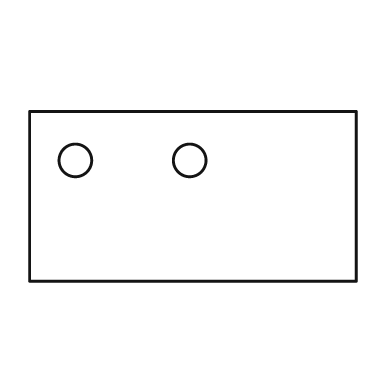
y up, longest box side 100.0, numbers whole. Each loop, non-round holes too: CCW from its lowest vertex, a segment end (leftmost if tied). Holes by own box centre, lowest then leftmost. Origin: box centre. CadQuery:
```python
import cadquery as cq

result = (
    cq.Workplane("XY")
    .moveTo(-50.0, -26.0)
    .lineTo(50.0, -26.0)
    .lineTo(50.0, 26.0)
    .lineTo(-50.0, 26.0)
    .close()
    .moveTo(-36.0, 11.0)
    .circle(5.0)
    .moveTo(-1.0, 11.0)
    .circle(5.0)
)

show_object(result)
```